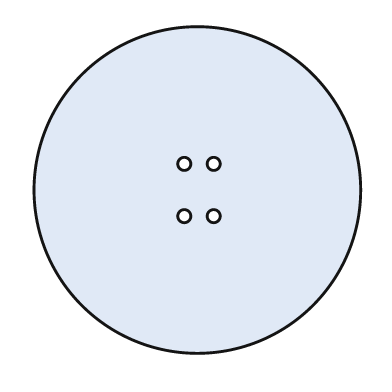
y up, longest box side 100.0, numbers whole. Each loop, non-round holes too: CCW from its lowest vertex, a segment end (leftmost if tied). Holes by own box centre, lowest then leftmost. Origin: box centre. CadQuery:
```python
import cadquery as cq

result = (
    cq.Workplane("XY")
    .moveTo(0.0, 0.0)
    .circle(50.0)
    .moveTo(-4.0, -8.0)
    .circle(2.0)
    .moveTo(5.0, -8.0)
    .circle(2.0)
    .moveTo(-4.0, 8.0)
    .circle(2.0)
    .moveTo(5.0, 8.0)
    .circle(2.0)
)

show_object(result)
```